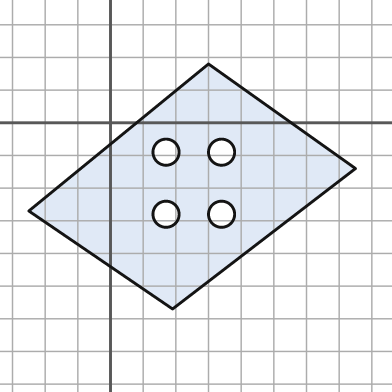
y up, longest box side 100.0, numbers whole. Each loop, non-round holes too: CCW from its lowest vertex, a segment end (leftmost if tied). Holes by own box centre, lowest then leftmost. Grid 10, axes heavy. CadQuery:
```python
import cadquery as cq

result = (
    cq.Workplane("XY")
    .moveTo(19.0, -57.0)
    .lineTo(75.0, -14.0)
    .lineTo(30.0, 18.0)
    .lineTo(-25.0, -27.0)
    .close()
    .moveTo(17.0, -28.0)
    .circle(4.0)
    .moveTo(34.0, -28.0)
    .circle(4.0)
    .moveTo(17.0, -9.0)
    .circle(4.0)
    .moveTo(34.0, -9.0)
    .circle(4.0)
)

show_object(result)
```